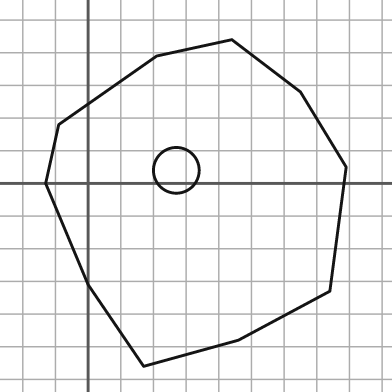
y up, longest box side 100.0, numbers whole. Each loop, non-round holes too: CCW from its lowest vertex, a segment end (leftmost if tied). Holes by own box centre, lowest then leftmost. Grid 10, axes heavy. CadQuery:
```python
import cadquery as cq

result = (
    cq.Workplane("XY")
    .moveTo(17.0, -56.0)
    .lineTo(46.0, -48.0)
    .lineTo(74.0, -33.0)
    .lineTo(79.0, 5.0)
    .lineTo(65.0, 28.0)
    .lineTo(44.0, 44.0)
    .lineTo(21.0, 39.0)
    .lineTo(-9.0, 18.0)
    .lineTo(-13.0, 0.0)
    .lineTo(0.0, -31.0)
    .close()
    .moveTo(27.0, 4.0)
    .circle(7.0)
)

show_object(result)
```